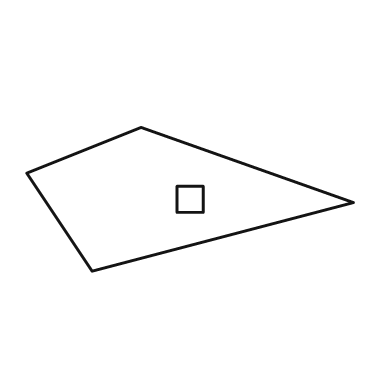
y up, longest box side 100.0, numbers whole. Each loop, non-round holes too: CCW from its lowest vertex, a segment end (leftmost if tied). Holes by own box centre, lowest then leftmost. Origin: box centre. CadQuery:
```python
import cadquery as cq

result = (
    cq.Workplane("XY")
    .moveTo(-30.0, -22.0)
    .lineTo(50.0, -1.0)
    .lineTo(-15.0, 22.0)
    .lineTo(-50.0, 8.0)
    .close()
    .moveTo(-4.0, -4.0)
    .lineTo(4.0, -4.0)
    .lineTo(4.0, 4.0)
    .lineTo(-4.0, 4.0)
    .close()
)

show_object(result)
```